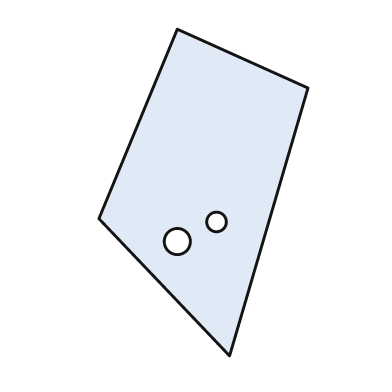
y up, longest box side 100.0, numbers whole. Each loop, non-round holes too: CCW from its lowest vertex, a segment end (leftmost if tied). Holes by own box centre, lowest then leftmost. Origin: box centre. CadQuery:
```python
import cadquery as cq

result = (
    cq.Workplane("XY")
    .moveTo(8.0, -50.0)
    .lineTo(32.0, 32.0)
    .lineTo(-8.0, 50.0)
    .lineTo(-32.0, -8.0)
    .close()
    .moveTo(-8.0, -15.0)
    .circle(4.0)
    .moveTo(4.0, -9.0)
    .circle(3.0)
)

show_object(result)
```